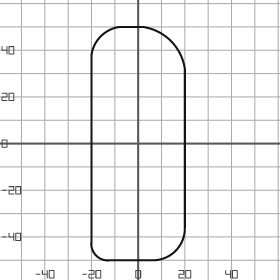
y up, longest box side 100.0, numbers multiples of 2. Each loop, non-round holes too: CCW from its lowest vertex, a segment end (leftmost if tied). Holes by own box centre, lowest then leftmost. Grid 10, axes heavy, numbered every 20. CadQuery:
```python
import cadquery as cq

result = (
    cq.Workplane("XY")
    .moveTo(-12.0, -50.0)
    .lineTo(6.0, -50.0)
    .threePointArc((16.0, -46.0), (20.0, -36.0))
    .lineTo(20.0, 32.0)
    .threePointArc((14.0, 44.0), (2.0, 50.0))
    .lineTo(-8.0, 50.0)
    .threePointArc((-16.0, 46.0), (-20.0, 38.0))
    .lineTo(-20.0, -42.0)
    .threePointArc((-18.0, -48.0), (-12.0, -50.0))
    .close()
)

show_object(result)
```